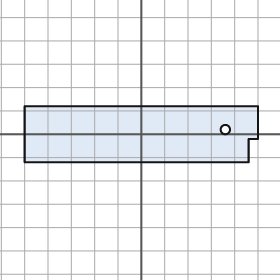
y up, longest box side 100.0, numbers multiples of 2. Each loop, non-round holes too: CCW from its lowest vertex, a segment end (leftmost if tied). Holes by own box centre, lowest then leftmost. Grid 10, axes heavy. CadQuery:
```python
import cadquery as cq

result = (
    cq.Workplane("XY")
    .moveTo(-50.0, -12.0)
    .lineTo(46.0, -12.0)
    .lineTo(46.0, -2.0)
    .lineTo(50.0, -2.0)
    .lineTo(50.0, 12.0)
    .lineTo(-50.0, 12.0)
    .close()
    .moveTo(36.0, 2.0)
    .circle(2.0)
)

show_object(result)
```